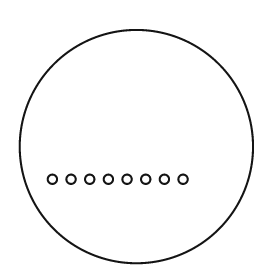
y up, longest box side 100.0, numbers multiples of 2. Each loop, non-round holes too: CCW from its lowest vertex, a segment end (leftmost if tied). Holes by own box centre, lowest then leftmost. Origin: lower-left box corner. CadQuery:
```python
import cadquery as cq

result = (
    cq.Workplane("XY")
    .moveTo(50.0, 50.0)
    .circle(50.0)
    .moveTo(14.0, 36.0)
    .circle(2.0)
    .moveTo(22.0, 36.0)
    .circle(2.0)
    .moveTo(30.0, 36.0)
    .circle(2.0)
    .moveTo(38.0, 36.0)
    .circle(2.0)
    .moveTo(46.0, 36.0)
    .circle(2.0)
    .moveTo(54.0, 36.0)
    .circle(2.0)
    .moveTo(62.0, 36.0)
    .circle(2.0)
    .moveTo(70.0, 36.0)
    .circle(2.0)
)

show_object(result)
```